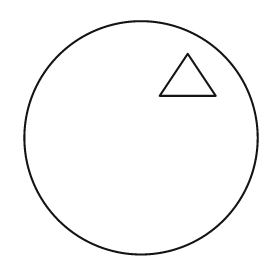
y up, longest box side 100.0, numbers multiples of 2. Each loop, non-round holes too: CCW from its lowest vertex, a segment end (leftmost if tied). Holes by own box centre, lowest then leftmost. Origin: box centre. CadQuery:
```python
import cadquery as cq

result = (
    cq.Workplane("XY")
    .moveTo(0.0, 0.0)
    .circle(50.0)
    .moveTo(8.0, 18.0)
    .lineTo(32.0, 18.0)
    .lineTo(20.0, 36.0)
    .close()
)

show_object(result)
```